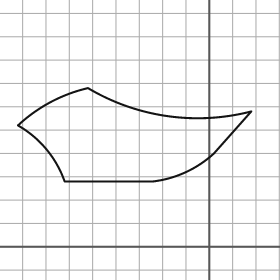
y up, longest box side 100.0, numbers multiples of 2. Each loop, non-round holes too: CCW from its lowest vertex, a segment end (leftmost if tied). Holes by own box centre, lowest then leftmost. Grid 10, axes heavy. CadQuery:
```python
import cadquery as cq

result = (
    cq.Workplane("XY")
    .moveTo(-62.0, 28.0)
    .lineTo(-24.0, 28.0)
    .threePointArc((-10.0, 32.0), (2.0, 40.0))
    .lineTo(18.0, 58.0)
    .threePointArc((-18.0, 56.0), (-52.0, 68.0))
    .threePointArc((-68.0, 62.0), (-82.0, 52.0))
    .threePointArc((-70.0, 42.0), (-62.0, 28.0))
    .close()
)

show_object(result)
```